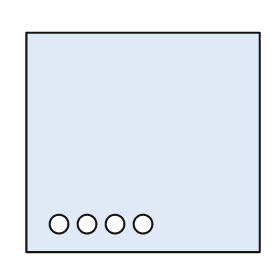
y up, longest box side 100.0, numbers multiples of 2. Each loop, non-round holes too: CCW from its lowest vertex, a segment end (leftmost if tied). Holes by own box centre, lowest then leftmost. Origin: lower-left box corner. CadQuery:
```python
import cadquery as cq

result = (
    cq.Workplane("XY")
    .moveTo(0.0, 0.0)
    .lineTo(100.0, 0.0)
    .lineTo(100.0, 94.0)
    .lineTo(0.0, 94.0)
    .close()
    .moveTo(14.0, 12.0)
    .circle(4.0)
    .moveTo(26.0, 12.0)
    .circle(4.0)
    .moveTo(38.0, 12.0)
    .circle(4.0)
    .moveTo(50.0, 12.0)
    .circle(4.0)
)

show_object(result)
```